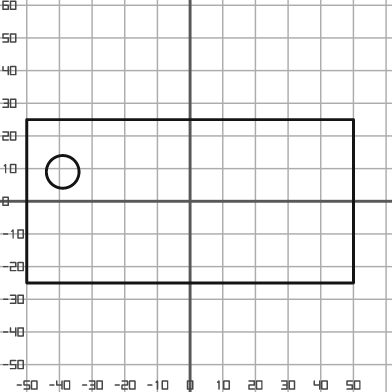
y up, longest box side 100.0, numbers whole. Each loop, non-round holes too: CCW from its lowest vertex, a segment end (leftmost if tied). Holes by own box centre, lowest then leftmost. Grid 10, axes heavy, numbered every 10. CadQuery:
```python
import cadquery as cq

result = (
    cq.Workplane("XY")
    .moveTo(-50.0, -25.0)
    .lineTo(50.0, -25.0)
    .lineTo(50.0, 25.0)
    .lineTo(-50.0, 25.0)
    .close()
    .moveTo(-39.0, 9.0)
    .circle(5.0)
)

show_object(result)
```